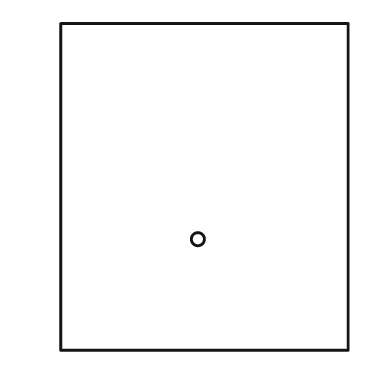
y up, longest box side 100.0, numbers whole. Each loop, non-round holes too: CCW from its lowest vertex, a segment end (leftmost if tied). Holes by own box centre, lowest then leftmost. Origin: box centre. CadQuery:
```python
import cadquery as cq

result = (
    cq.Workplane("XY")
    .moveTo(-44.0, -50.0)
    .lineTo(44.0, -50.0)
    .lineTo(44.0, 50.0)
    .lineTo(-44.0, 50.0)
    .close()
    .moveTo(-2.0, -16.0)
    .circle(2.0)
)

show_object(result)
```